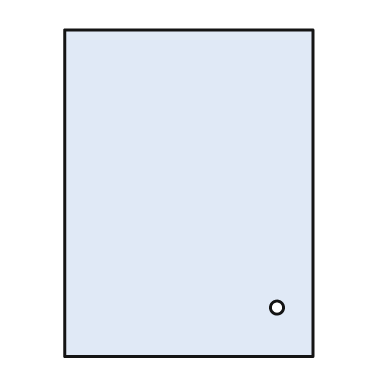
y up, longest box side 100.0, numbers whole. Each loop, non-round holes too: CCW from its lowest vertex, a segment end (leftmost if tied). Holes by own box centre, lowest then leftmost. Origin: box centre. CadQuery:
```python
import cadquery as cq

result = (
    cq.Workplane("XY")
    .moveTo(-38.0, -50.0)
    .lineTo(38.0, -50.0)
    .lineTo(38.0, 50.0)
    .lineTo(-38.0, 50.0)
    .close()
    .moveTo(27.0, -35.0)
    .circle(2.0)
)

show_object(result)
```